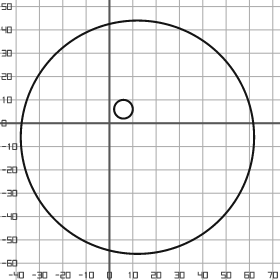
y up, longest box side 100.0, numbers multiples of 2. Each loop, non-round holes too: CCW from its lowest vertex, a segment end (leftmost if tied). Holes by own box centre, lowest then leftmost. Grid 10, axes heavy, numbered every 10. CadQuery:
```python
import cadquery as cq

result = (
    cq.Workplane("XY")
    .moveTo(12.0, -6.0)
    .circle(50.0)
    .moveTo(6.0, 6.0)
    .circle(4.0)
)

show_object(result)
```